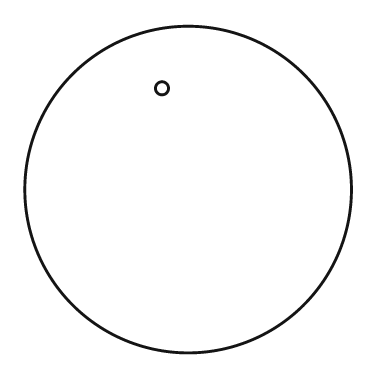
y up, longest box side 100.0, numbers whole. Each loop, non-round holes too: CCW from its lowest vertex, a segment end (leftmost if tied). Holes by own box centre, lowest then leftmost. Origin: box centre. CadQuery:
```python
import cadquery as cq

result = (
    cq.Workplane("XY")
    .moveTo(0.0, 0.0)
    .circle(50.0)
    .moveTo(-8.0, 31.0)
    .circle(2.0)
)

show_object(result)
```